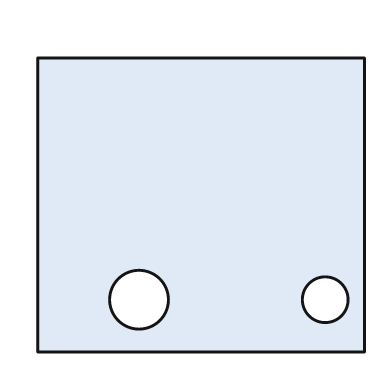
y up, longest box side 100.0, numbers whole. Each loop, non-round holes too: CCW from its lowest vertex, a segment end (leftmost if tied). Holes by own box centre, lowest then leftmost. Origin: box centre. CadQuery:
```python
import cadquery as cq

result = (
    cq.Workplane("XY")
    .moveTo(-50.0, -45.0)
    .lineTo(50.0, -45.0)
    .lineTo(50.0, 45.0)
    .lineTo(-50.0, 45.0)
    .close()
    .moveTo(-19.0, -29.0)
    .circle(9.0)
    .moveTo(38.0, -29.0)
    .circle(7.0)
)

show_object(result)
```